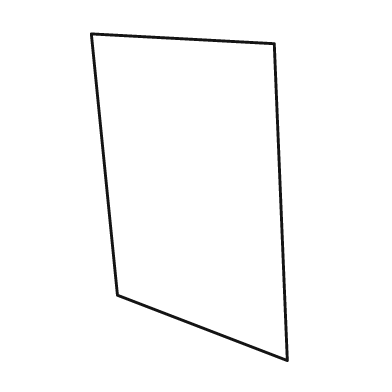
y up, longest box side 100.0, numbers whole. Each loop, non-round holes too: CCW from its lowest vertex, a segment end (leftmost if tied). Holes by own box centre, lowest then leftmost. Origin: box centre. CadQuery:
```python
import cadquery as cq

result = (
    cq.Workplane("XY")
    .moveTo(30.0, -50.0)
    .lineTo(26.0, 47.0)
    .lineTo(-30.0, 50.0)
    .lineTo(-22.0, -30.0)
    .close()
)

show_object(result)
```